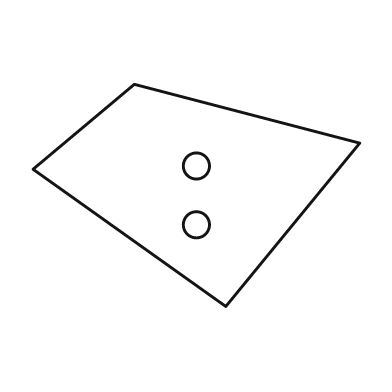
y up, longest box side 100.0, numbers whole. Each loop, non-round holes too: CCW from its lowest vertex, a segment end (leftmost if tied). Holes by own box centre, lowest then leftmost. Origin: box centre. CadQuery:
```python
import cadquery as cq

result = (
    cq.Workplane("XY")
    .moveTo(9.0, -34.0)
    .lineTo(50.0, 16.0)
    .lineTo(-19.0, 34.0)
    .lineTo(-50.0, 8.0)
    .close()
    .moveTo(0.0, -9.0)
    .circle(4.0)
    .moveTo(0.0, 9.0)
    .circle(4.0)
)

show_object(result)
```